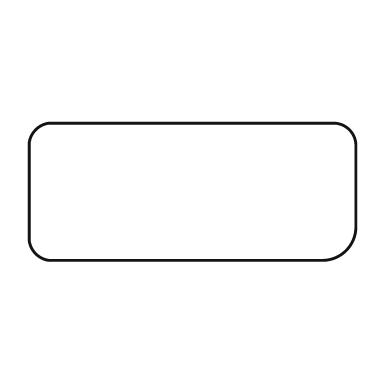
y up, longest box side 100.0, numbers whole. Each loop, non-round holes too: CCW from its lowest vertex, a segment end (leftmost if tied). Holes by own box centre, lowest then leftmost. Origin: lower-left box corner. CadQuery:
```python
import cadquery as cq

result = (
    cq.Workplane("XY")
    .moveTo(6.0, 0.0)
    .lineTo(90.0, 0.0)
    .threePointArc((97.0, 3.0), (100.0, 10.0))
    .lineTo(100.0, 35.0)
    .threePointArc((98.0, 40.0), (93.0, 42.0))
    .lineTo(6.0, 42.0)
    .threePointArc((2.0, 40.0), (0.0, 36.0))
    .lineTo(0.0, 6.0)
    .threePointArc((2.0, 2.0), (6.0, 0.0))
    .close()
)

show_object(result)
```